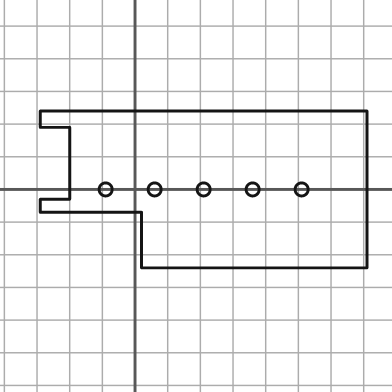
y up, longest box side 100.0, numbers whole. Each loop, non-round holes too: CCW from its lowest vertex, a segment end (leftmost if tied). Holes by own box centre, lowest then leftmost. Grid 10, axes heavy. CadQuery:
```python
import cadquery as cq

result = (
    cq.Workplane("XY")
    .moveTo(2.0, -24.0)
    .lineTo(71.0, -24.0)
    .lineTo(71.0, 24.0)
    .lineTo(-29.0, 24.0)
    .lineTo(-29.0, 19.0)
    .lineTo(-20.0, 19.0)
    .lineTo(-20.0, -3.0)
    .lineTo(-29.0, -3.0)
    .lineTo(-29.0, -7.0)
    .lineTo(2.0, -7.0)
    .close()
    .moveTo(-9.0, 0.0)
    .circle(2.0)
    .moveTo(6.0, 0.0)
    .circle(2.0)
    .moveTo(21.0, 0.0)
    .circle(2.0)
    .moveTo(36.0, 0.0)
    .circle(2.0)
    .moveTo(51.0, 0.0)
    .circle(2.0)
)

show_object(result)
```